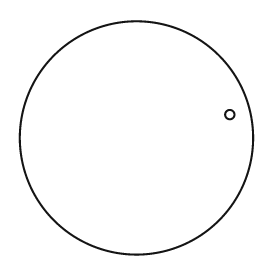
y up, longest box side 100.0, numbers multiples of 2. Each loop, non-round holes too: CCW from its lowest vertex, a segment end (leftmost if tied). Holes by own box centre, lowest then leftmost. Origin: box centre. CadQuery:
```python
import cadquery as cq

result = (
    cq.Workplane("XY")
    .moveTo(0.0, 0.0)
    .circle(50.0)
    .moveTo(40.0, 10.0)
    .circle(2.0)
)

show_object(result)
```